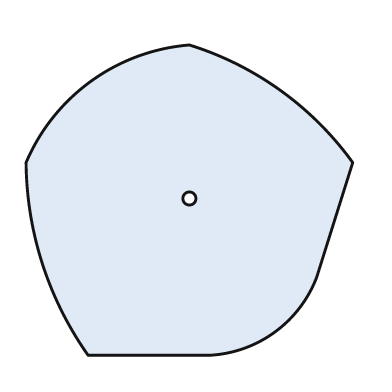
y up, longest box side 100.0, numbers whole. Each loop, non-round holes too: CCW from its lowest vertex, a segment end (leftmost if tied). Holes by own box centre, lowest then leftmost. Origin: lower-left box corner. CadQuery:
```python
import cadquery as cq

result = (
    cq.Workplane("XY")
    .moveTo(19.0, 0.0)
    .lineTo(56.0, 0.0)
    .threePointArc((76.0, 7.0), (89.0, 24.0))
    .lineTo(100.0, 59.0)
    .threePointArc((78.0, 81.0), (50.0, 95.0))
    .threePointArc((20.0, 84.0), (0.0, 59.0))
    .threePointArc((5.0, 28.0), (19.0, 0.0))
    .close()
    .moveTo(50.0, 48.0)
    .circle(2.0)
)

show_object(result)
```